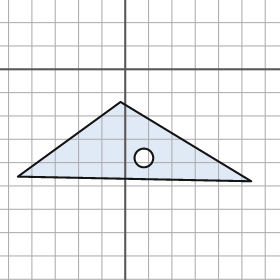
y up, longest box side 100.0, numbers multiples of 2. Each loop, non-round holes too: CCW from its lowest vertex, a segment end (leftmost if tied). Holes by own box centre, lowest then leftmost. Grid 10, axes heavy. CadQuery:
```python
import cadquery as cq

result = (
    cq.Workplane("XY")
    .moveTo(54.0, -48.0)
    .lineTo(-2.0, -14.0)
    .lineTo(-46.0, -46.0)
    .close()
    .moveTo(8.0, -38.0)
    .circle(4.0)
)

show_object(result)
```